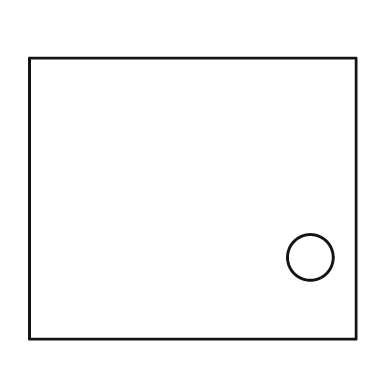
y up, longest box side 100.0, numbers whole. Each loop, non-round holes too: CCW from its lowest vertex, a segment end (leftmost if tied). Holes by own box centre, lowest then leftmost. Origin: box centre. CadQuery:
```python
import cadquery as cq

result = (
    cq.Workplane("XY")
    .moveTo(-50.0, -43.0)
    .lineTo(50.0, -43.0)
    .lineTo(50.0, 43.0)
    .lineTo(-50.0, 43.0)
    .close()
    .moveTo(36.0, -18.0)
    .circle(7.0)
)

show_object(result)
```